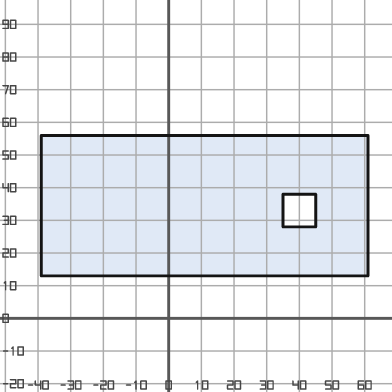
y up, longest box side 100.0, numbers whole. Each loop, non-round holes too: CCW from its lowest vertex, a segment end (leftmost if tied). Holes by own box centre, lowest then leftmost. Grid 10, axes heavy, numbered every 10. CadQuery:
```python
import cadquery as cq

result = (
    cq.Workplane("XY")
    .moveTo(-39.0, 13.0)
    .lineTo(61.0, 13.0)
    .lineTo(61.0, 56.0)
    .lineTo(-39.0, 56.0)
    .close()
    .moveTo(35.0, 28.0)
    .lineTo(45.0, 28.0)
    .lineTo(45.0, 38.0)
    .lineTo(35.0, 38.0)
    .close()
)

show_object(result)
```